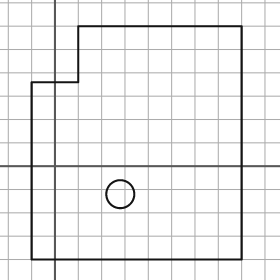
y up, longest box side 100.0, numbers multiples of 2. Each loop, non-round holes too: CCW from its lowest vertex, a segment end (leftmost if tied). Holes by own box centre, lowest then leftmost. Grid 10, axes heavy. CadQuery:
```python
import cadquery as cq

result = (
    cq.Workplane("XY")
    .moveTo(-10.0, -40.0)
    .lineTo(80.0, -40.0)
    .lineTo(80.0, 60.0)
    .lineTo(10.0, 60.0)
    .lineTo(10.0, 36.0)
    .lineTo(-10.0, 36.0)
    .close()
    .moveTo(28.0, -12.0)
    .circle(6.0)
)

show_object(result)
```